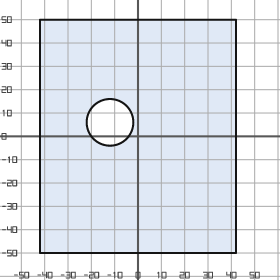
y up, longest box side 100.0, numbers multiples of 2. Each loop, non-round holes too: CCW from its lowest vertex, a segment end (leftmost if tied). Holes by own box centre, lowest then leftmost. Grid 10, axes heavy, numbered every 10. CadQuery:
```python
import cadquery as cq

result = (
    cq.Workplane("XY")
    .moveTo(-42.0, -50.0)
    .lineTo(42.0, -50.0)
    .lineTo(42.0, 50.0)
    .lineTo(-42.0, 50.0)
    .close()
    .moveTo(-12.0, 6.0)
    .circle(10.0)
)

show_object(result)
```